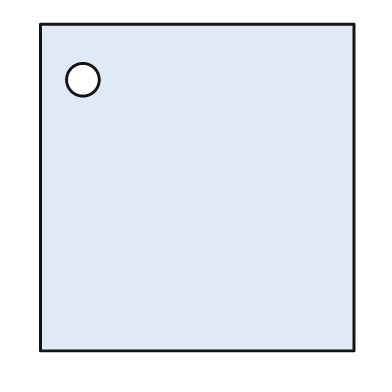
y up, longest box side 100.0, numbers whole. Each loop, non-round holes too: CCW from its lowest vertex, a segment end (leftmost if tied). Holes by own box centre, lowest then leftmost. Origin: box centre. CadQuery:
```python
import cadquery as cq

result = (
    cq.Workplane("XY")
    .moveTo(-48.0, -50.0)
    .lineTo(48.0, -50.0)
    .lineTo(48.0, 50.0)
    .lineTo(-48.0, 50.0)
    .close()
    .moveTo(-35.0, 33.0)
    .circle(5.0)
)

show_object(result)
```